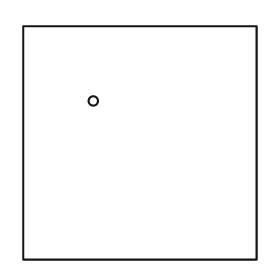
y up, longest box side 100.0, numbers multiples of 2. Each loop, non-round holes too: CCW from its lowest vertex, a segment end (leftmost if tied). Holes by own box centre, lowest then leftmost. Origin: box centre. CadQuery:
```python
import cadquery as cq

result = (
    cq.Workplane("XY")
    .moveTo(-50.0, -50.0)
    .lineTo(50.0, -50.0)
    .lineTo(50.0, 50.0)
    .lineTo(-50.0, 50.0)
    .close()
    .moveTo(-20.0, 18.0)
    .circle(2.0)
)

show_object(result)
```